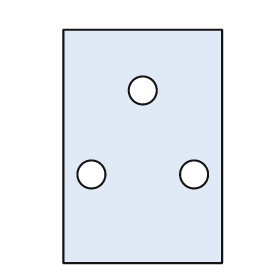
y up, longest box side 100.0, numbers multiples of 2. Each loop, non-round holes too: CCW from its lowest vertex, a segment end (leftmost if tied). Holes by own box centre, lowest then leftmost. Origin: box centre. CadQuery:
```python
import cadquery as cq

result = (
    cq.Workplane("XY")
    .moveTo(-34.0, -50.0)
    .lineTo(34.0, -50.0)
    .lineTo(34.0, 50.0)
    .lineTo(-34.0, 50.0)
    .close()
    .moveTo(-22.0, -12.0)
    .circle(6.0)
    .moveTo(22.0, -12.0)
    .circle(6.0)
    .moveTo(0.0, 24.0)
    .circle(6.0)
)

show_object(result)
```